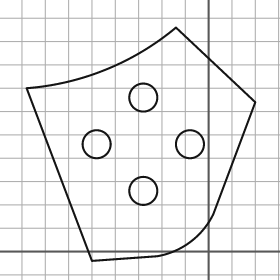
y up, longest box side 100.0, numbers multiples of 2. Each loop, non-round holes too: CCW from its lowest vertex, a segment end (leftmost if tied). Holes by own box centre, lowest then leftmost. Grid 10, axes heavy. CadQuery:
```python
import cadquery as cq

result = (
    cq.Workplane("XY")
    .moveTo(-50.0, -4.0)
    .lineTo(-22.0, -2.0)
    .threePointArc((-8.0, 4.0), (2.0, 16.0))
    .lineTo(20.0, 64.0)
    .lineTo(-14.0, 96.0)
    .threePointArc((-44.0, 78.0), (-78.0, 70.0))
    .close()
    .moveTo(-28.0, 26.0)
    .circle(6.0)
    .moveTo(-48.0, 46.0)
    .circle(6.0)
    .moveTo(-8.0, 46.0)
    .circle(6.0)
    .moveTo(-28.0, 66.0)
    .circle(6.0)
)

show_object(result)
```